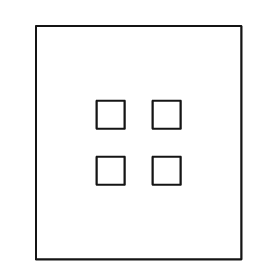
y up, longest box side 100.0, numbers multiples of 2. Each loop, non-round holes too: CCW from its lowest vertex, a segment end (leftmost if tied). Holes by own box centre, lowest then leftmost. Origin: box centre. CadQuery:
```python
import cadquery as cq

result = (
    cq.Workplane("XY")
    .moveTo(-44.0, -50.0)
    .lineTo(44.0, -50.0)
    .lineTo(44.0, 50.0)
    .lineTo(-44.0, 50.0)
    .close()
    .moveTo(-18.0, -18.0)
    .lineTo(-6.0, -18.0)
    .lineTo(-6.0, -6.0)
    .lineTo(-18.0, -6.0)
    .close()
    .moveTo(6.0, -18.0)
    .lineTo(18.0, -18.0)
    .lineTo(18.0, -6.0)
    .lineTo(6.0, -6.0)
    .close()
    .moveTo(-18.0, 6.0)
    .lineTo(-6.0, 6.0)
    .lineTo(-6.0, 18.0)
    .lineTo(-18.0, 18.0)
    .close()
    .moveTo(6.0, 6.0)
    .lineTo(18.0, 6.0)
    .lineTo(18.0, 18.0)
    .lineTo(6.0, 18.0)
    .close()
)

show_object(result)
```